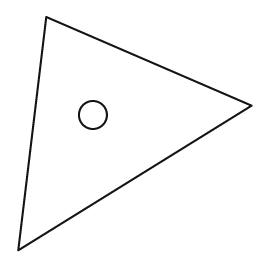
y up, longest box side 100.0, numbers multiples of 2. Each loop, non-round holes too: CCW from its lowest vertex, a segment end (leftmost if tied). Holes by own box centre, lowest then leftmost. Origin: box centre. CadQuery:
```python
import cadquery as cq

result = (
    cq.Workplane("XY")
    .moveTo(-50.0, -50.0)
    .lineTo(50.0, 12.0)
    .lineTo(-38.0, 50.0)
    .close()
    .moveTo(-18.0, 8.0)
    .circle(6.0)
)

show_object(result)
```